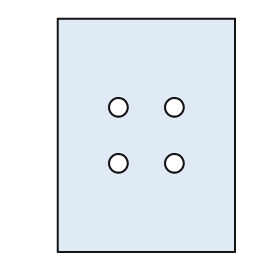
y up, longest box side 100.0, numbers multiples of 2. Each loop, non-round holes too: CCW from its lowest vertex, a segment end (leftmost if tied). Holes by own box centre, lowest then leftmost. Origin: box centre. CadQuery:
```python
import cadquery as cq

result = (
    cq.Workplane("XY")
    .moveTo(-38.0, -50.0)
    .lineTo(38.0, -50.0)
    .lineTo(38.0, 50.0)
    .lineTo(-38.0, 50.0)
    .close()
    .moveTo(-12.0, -12.0)
    .circle(4.0)
    .moveTo(12.0, -12.0)
    .circle(4.0)
    .moveTo(-12.0, 12.0)
    .circle(4.0)
    .moveTo(12.0, 12.0)
    .circle(4.0)
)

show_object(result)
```